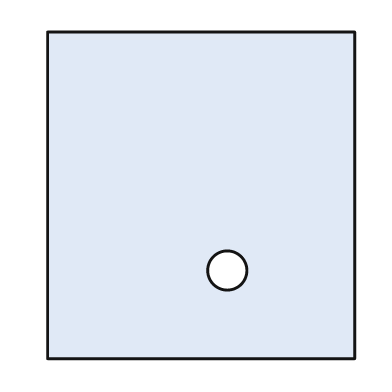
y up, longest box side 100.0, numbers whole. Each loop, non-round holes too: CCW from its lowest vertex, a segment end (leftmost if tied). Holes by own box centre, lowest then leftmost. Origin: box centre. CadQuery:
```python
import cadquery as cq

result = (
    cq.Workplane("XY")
    .moveTo(-47.0, -50.0)
    .lineTo(47.0, -50.0)
    .lineTo(47.0, 50.0)
    .lineTo(-47.0, 50.0)
    .close()
    .moveTo(8.0, -23.0)
    .circle(6.0)
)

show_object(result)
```